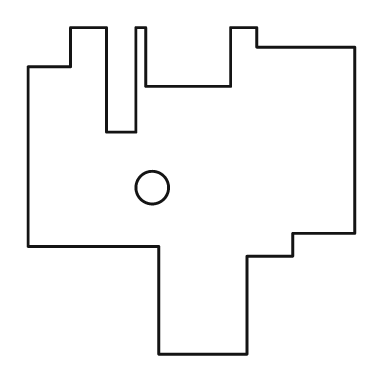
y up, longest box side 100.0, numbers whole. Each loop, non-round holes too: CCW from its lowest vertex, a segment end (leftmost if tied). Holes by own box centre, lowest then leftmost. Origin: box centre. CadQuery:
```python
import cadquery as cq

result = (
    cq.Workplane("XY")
    .moveTo(-10.0, -50.0)
    .lineTo(17.0, -50.0)
    .lineTo(17.0, -20.0)
    .lineTo(31.0, -20.0)
    .lineTo(31.0, -13.0)
    .lineTo(50.0, -13.0)
    .lineTo(50.0, 44.0)
    .lineTo(20.0, 44.0)
    .lineTo(20.0, 50.0)
    .lineTo(12.0, 50.0)
    .lineTo(12.0, 32.0)
    .lineTo(-14.0, 32.0)
    .lineTo(-14.0, 50.0)
    .lineTo(-17.0, 50.0)
    .lineTo(-17.0, 18.0)
    .lineTo(-26.0, 18.0)
    .lineTo(-26.0, 50.0)
    .lineTo(-37.0, 50.0)
    .lineTo(-37.0, 38.0)
    .lineTo(-50.0, 38.0)
    .lineTo(-50.0, -17.0)
    .lineTo(-10.0, -17.0)
    .close()
    .moveTo(-12.0, 1.0)
    .circle(5.0)
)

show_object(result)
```